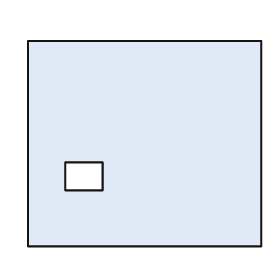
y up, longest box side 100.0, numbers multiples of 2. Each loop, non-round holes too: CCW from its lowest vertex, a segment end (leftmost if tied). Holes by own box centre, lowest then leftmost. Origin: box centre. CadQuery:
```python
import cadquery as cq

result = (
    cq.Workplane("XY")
    .moveTo(-50.0, -44.0)
    .lineTo(50.0, -44.0)
    .lineTo(50.0, 44.0)
    .lineTo(-50.0, 44.0)
    .close()
    .moveTo(-34.0, -20.0)
    .lineTo(-18.0, -20.0)
    .lineTo(-18.0, -8.0)
    .lineTo(-34.0, -8.0)
    .close()
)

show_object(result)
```